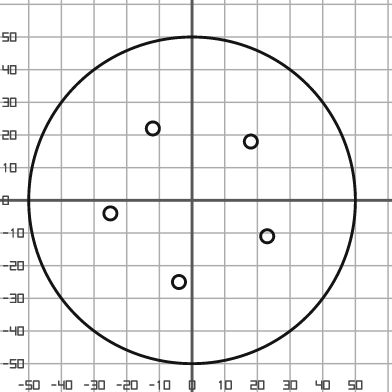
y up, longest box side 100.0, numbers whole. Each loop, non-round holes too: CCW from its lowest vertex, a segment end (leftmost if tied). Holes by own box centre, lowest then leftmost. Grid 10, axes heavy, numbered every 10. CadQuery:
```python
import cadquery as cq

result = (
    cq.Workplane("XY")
    .moveTo(0.0, 0.0)
    .circle(50.0)
    .moveTo(-4.0, -25.0)
    .circle(2.0)
    .moveTo(23.0, -11.0)
    .circle(2.0)
    .moveTo(-25.0, -4.0)
    .circle(2.0)
    .moveTo(18.0, 18.0)
    .circle(2.0)
    .moveTo(-12.0, 22.0)
    .circle(2.0)
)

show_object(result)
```